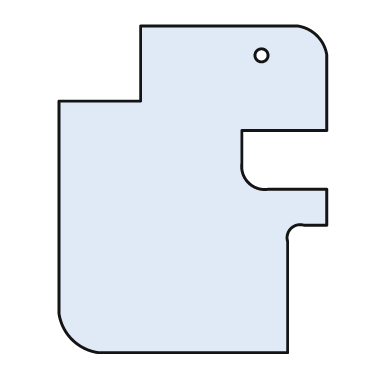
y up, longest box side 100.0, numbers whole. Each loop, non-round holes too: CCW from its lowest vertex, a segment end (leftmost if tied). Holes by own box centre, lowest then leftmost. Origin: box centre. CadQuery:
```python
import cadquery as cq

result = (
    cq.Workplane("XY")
    .moveTo(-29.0, -50.0)
    .lineTo(29.0, -50.0)
    .lineTo(29.0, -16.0)
    .threePointArc((30.0, -12.0), (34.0, -11.0))
    .lineTo(41.0, -11.0)
    .lineTo(41.0, 0.0)
    .lineTo(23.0, 0.0)
    .threePointArc((17.0, 2.0), (15.0, 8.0))
    .lineTo(15.0, 18.0)
    .lineTo(41.0, 18.0)
    .lineTo(41.0, 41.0)
    .threePointArc((38.0, 47.0), (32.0, 50.0))
    .lineTo(-16.0, 50.0)
    .lineTo(-16.0, 27.0)
    .lineTo(-41.0, 27.0)
    .lineTo(-41.0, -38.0)
    .threePointArc((-37.0, -46.0), (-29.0, -50.0))
    .close()
    .moveTo(21.0, 41.0)
    .circle(2.0)
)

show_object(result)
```